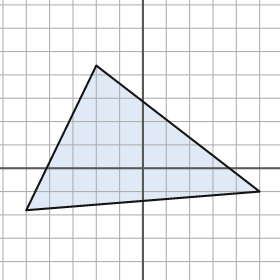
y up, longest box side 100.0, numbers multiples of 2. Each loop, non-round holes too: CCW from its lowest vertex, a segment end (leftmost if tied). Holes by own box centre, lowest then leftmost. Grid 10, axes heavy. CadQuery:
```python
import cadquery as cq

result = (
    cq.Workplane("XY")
    .moveTo(-50.0, -18.0)
    .lineTo(50.0, -10.0)
    .lineTo(-20.0, 44.0)
    .close()
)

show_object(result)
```